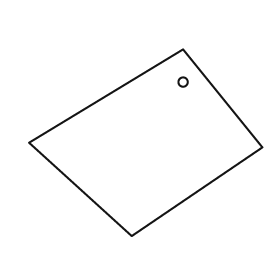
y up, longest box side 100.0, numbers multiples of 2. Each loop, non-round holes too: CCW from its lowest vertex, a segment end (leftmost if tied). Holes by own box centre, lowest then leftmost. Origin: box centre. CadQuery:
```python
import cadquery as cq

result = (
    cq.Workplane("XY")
    .moveTo(-6.0, -40.0)
    .lineTo(50.0, -2.0)
    .lineTo(16.0, 40.0)
    .lineTo(-50.0, 0.0)
    .close()
    .moveTo(16.0, 26.0)
    .circle(2.0)
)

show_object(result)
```